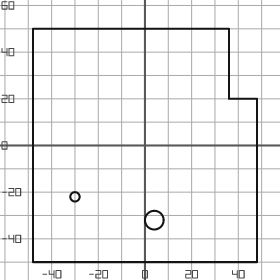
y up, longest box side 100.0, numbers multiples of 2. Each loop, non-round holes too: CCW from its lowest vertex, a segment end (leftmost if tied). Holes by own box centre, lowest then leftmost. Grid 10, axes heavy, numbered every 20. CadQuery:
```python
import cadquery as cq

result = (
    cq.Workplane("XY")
    .moveTo(-48.0, -50.0)
    .lineTo(48.0, -50.0)
    .lineTo(48.0, 20.0)
    .lineTo(36.0, 20.0)
    .lineTo(36.0, 50.0)
    .lineTo(-48.0, 50.0)
    .close()
    .moveTo(4.0, -32.0)
    .circle(4.0)
    .moveTo(-30.0, -22.0)
    .circle(2.0)
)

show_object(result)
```